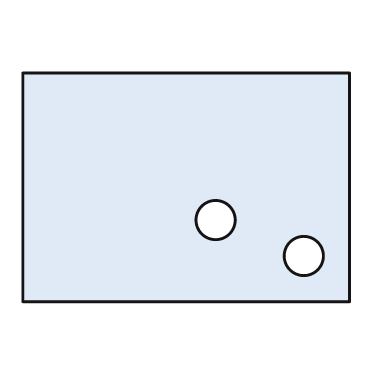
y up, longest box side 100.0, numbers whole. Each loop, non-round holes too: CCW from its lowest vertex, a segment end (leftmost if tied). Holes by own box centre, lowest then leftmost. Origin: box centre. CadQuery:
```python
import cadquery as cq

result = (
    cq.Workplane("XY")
    .moveTo(-50.0, -35.0)
    .lineTo(50.0, -35.0)
    .lineTo(50.0, 35.0)
    .lineTo(-50.0, 35.0)
    .close()
    .moveTo(36.0, -21.0)
    .circle(6.0)
    .moveTo(9.0, -10.0)
    .circle(6.0)
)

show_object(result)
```